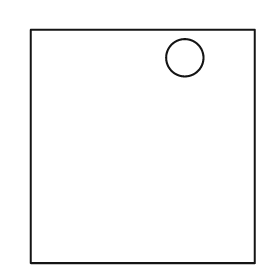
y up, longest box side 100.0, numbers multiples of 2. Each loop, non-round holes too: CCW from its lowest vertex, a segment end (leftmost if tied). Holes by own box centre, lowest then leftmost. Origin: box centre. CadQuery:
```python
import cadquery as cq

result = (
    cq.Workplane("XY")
    .moveTo(-48.0, -50.0)
    .lineTo(48.0, -50.0)
    .lineTo(48.0, 50.0)
    .lineTo(-48.0, 50.0)
    .close()
    .moveTo(18.0, 38.0)
    .circle(8.0)
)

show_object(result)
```